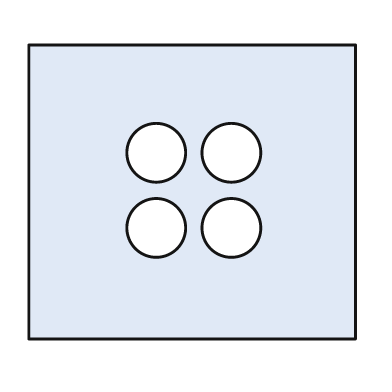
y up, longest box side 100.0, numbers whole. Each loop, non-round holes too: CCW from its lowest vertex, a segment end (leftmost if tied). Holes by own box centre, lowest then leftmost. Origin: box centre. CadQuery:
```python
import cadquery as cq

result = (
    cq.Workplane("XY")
    .moveTo(-50.0, -45.0)
    .lineTo(50.0, -45.0)
    .lineTo(50.0, 45.0)
    .lineTo(-50.0, 45.0)
    .close()
    .moveTo(-11.0, -11.0)
    .circle(9.0)
    .moveTo(12.0, -11.0)
    .circle(9.0)
    .moveTo(-11.0, 12.0)
    .circle(9.0)
    .moveTo(12.0, 12.0)
    .circle(9.0)
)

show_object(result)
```